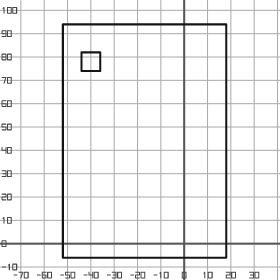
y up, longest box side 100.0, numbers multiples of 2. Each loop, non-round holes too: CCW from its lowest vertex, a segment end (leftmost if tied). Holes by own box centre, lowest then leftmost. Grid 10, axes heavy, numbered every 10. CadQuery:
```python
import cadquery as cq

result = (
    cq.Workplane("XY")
    .moveTo(-52.0, -6.0)
    .lineTo(18.0, -6.0)
    .lineTo(18.0, 94.0)
    .lineTo(-52.0, 94.0)
    .close()
    .moveTo(-44.0, 74.0)
    .lineTo(-36.0, 74.0)
    .lineTo(-36.0, 82.0)
    .lineTo(-44.0, 82.0)
    .close()
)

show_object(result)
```